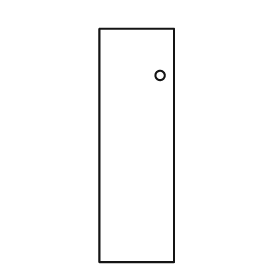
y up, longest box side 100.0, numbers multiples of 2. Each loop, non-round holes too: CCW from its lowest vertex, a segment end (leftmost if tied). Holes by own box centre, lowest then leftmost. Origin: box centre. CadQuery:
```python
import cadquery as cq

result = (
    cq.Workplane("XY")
    .moveTo(-16.0, -50.0)
    .lineTo(16.0, -50.0)
    .lineTo(16.0, 50.0)
    .lineTo(-16.0, 50.0)
    .close()
    .moveTo(10.0, 30.0)
    .circle(2.0)
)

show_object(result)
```